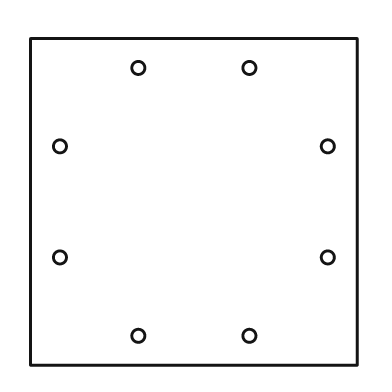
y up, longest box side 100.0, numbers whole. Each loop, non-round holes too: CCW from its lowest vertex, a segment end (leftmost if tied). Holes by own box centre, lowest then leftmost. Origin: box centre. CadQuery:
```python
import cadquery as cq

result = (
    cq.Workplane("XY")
    .moveTo(-50.0, -50.0)
    .lineTo(50.0, -50.0)
    .lineTo(50.0, 50.0)
    .lineTo(-50.0, 50.0)
    .close()
    .moveTo(-17.0, -41.0)
    .circle(2.0)
    .moveTo(17.0, -41.0)
    .circle(2.0)
    .moveTo(-41.0, -17.0)
    .circle(2.0)
    .moveTo(41.0, -17.0)
    .circle(2.0)
    .moveTo(-41.0, 17.0)
    .circle(2.0)
    .moveTo(41.0, 17.0)
    .circle(2.0)
    .moveTo(-17.0, 41.0)
    .circle(2.0)
    .moveTo(17.0, 41.0)
    .circle(2.0)
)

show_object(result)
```